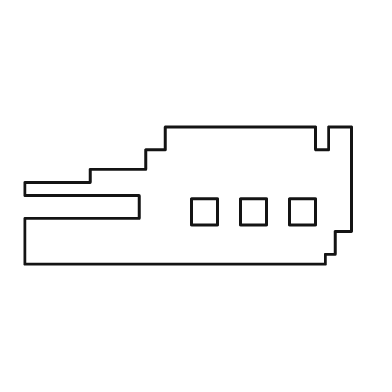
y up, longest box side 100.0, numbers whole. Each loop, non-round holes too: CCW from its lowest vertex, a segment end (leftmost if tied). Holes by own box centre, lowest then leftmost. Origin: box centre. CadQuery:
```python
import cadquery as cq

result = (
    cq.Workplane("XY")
    .moveTo(-50.0, -21.0)
    .lineTo(42.0, -21.0)
    .lineTo(42.0, -18.0)
    .lineTo(45.0, -18.0)
    .lineTo(45.0, -11.0)
    .lineTo(50.0, -11.0)
    .lineTo(50.0, 21.0)
    .lineTo(43.0, 21.0)
    .lineTo(43.0, 14.0)
    .lineTo(39.0, 14.0)
    .lineTo(39.0, 21.0)
    .lineTo(-7.0, 21.0)
    .lineTo(-7.0, 14.0)
    .lineTo(-13.0, 14.0)
    .lineTo(-13.0, 8.0)
    .lineTo(-30.0, 8.0)
    .lineTo(-30.0, 4.0)
    .lineTo(-50.0, 4.0)
    .lineTo(-50.0, 0.0)
    .lineTo(-15.0, 0.0)
    .lineTo(-15.0, -7.0)
    .lineTo(-50.0, -7.0)
    .close()
    .moveTo(1.0, -9.0)
    .lineTo(9.0, -9.0)
    .lineTo(9.0, -1.0)
    .lineTo(1.0, -1.0)
    .close()
    .moveTo(16.0, -9.0)
    .lineTo(24.0, -9.0)
    .lineTo(24.0, -1.0)
    .lineTo(16.0, -1.0)
    .close()
    .moveTo(31.0, -9.0)
    .lineTo(39.0, -9.0)
    .lineTo(39.0, -1.0)
    .lineTo(31.0, -1.0)
    .close()
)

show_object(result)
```